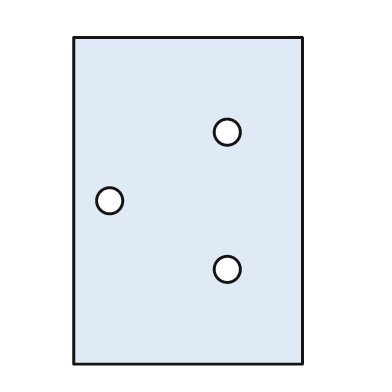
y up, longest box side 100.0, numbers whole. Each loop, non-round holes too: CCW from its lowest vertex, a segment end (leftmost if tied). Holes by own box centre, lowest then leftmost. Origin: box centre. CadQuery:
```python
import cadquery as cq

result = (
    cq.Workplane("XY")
    .moveTo(-35.0, -50.0)
    .lineTo(35.0, -50.0)
    .lineTo(35.0, 50.0)
    .lineTo(-35.0, 50.0)
    .close()
    .moveTo(12.0, -21.0)
    .circle(4.0)
    .moveTo(-24.0, 0.0)
    .circle(4.0)
    .moveTo(12.0, 21.0)
    .circle(4.0)
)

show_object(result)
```